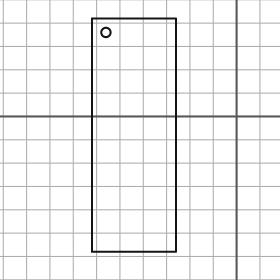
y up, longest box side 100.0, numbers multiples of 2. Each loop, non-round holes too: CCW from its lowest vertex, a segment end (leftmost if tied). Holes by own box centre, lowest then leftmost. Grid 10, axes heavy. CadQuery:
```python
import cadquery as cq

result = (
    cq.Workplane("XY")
    .moveTo(-62.0, -58.0)
    .lineTo(-26.0, -58.0)
    .lineTo(-26.0, 42.0)
    .lineTo(-62.0, 42.0)
    .close()
    .moveTo(-56.0, 36.0)
    .circle(2.0)
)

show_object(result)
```